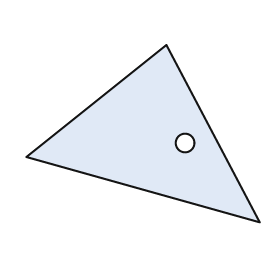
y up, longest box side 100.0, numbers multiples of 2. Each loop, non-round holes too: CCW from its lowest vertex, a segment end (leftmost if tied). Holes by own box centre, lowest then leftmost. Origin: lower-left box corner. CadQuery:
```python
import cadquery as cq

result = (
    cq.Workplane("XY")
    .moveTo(100.0, 0.0)
    .lineTo(60.0, 76.0)
    .lineTo(0.0, 28.0)
    .close()
    .moveTo(68.0, 34.0)
    .circle(4.0)
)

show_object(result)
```